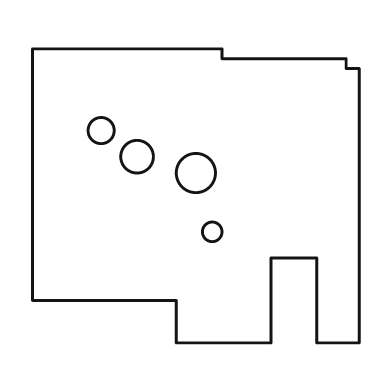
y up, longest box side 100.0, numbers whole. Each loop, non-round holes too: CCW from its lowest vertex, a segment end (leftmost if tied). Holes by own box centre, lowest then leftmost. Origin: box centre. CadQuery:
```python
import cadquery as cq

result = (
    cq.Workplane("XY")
    .moveTo(-6.0, -45.0)
    .lineTo(23.0, -45.0)
    .lineTo(23.0, -19.0)
    .lineTo(37.0, -19.0)
    .lineTo(37.0, -45.0)
    .lineTo(50.0, -45.0)
    .lineTo(50.0, 39.0)
    .lineTo(46.0, 39.0)
    .lineTo(46.0, 42.0)
    .lineTo(8.0, 42.0)
    .lineTo(8.0, 45.0)
    .lineTo(-50.0, 45.0)
    .lineTo(-50.0, -32.0)
    .lineTo(-6.0, -32.0)
    .close()
    .moveTo(5.0, -11.0)
    .circle(3.0)
    .moveTo(0.0, 7.0)
    .circle(6.0)
    .moveTo(-18.0, 12.0)
    .circle(5.0)
    .moveTo(-29.0, 20.0)
    .circle(4.0)
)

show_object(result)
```